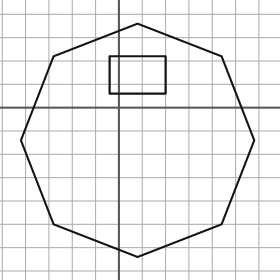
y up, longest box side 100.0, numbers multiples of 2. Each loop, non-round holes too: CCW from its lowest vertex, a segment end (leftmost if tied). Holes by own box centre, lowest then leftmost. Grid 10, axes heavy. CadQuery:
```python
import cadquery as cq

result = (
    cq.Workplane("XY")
    .moveTo(8.0, -64.0)
    .lineTo(44.0, -50.0)
    .lineTo(58.0, -14.0)
    .lineTo(44.0, 22.0)
    .lineTo(8.0, 36.0)
    .lineTo(-28.0, 22.0)
    .lineTo(-42.0, -14.0)
    .lineTo(-28.0, -50.0)
    .close()
    .moveTo(-4.0, 6.0)
    .lineTo(20.0, 6.0)
    .lineTo(20.0, 22.0)
    .lineTo(-4.0, 22.0)
    .close()
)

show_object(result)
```